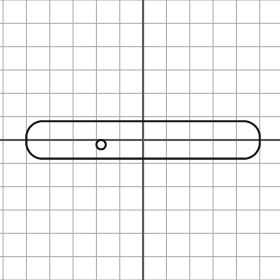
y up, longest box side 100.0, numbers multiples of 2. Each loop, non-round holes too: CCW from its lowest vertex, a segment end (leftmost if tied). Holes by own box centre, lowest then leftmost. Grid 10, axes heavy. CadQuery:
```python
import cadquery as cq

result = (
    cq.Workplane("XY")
    .moveTo(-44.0, -8.0)
    .lineTo(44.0, -8.0)
    .threePointArc((48.0, -6.0), (50.0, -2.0))
    .lineTo(50.0, 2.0)
    .threePointArc((48.0, 6.0), (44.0, 8.0))
    .lineTo(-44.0, 8.0)
    .threePointArc((-48.0, 6.0), (-50.0, 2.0))
    .lineTo(-50.0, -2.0)
    .threePointArc((-48.0, -6.0), (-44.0, -8.0))
    .close()
    .moveTo(-18.0, -2.0)
    .circle(2.0)
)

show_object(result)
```